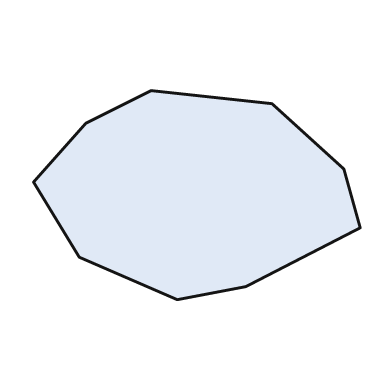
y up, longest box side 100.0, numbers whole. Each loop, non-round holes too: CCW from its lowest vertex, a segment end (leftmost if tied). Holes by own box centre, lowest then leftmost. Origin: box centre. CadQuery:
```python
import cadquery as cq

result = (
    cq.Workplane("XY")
    .moveTo(-6.0, -32.0)
    .lineTo(15.0, -28.0)
    .lineTo(50.0, -10.0)
    .lineTo(45.0, 8.0)
    .lineTo(23.0, 28.0)
    .lineTo(-14.0, 32.0)
    .lineTo(-34.0, 22.0)
    .lineTo(-50.0, 4.0)
    .lineTo(-36.0, -19.0)
    .close()
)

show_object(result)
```